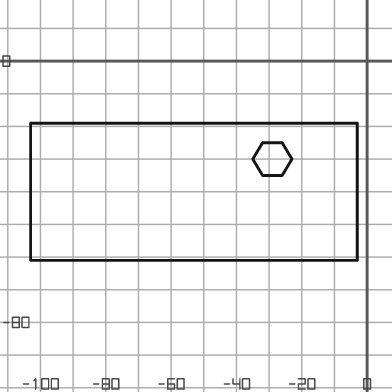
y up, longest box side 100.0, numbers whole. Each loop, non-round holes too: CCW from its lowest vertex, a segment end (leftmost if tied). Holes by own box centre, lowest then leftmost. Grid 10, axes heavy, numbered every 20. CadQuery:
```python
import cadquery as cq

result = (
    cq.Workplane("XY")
    .moveTo(-103.0, -61.0)
    .lineTo(-3.0, -61.0)
    .lineTo(-3.0, -19.0)
    .lineTo(-103.0, -19.0)
    .close()
    .moveTo(-32.0, -35.0)
    .lineTo(-26.0, -35.0)
    .lineTo(-23.0, -30.0)
    .lineTo(-26.0, -25.0)
    .lineTo(-32.0, -25.0)
    .lineTo(-35.0, -30.0)
    .close()
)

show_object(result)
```